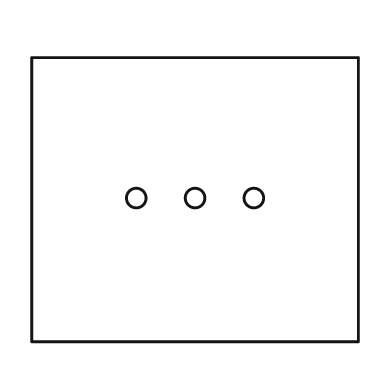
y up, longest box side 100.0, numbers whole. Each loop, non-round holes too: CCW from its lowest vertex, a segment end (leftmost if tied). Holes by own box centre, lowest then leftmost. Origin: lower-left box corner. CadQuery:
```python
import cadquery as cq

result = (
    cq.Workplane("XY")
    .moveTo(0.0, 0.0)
    .lineTo(100.0, 0.0)
    .lineTo(100.0, 87.0)
    .lineTo(0.0, 87.0)
    .close()
    .moveTo(32.0, 44.0)
    .circle(3.0)
    .moveTo(50.0, 44.0)
    .circle(3.0)
    .moveTo(68.0, 44.0)
    .circle(3.0)
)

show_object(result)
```